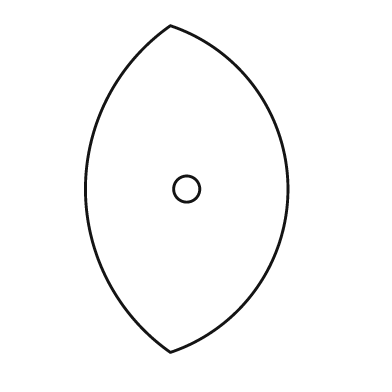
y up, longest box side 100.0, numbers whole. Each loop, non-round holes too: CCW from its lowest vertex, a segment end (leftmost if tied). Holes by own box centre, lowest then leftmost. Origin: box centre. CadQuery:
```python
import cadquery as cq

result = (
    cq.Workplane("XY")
    .moveTo(-5.0, -50.0)
    .threePointArc((31.0, 0.0), (-5.0, 50.0))
    .threePointArc((-31.0, 0.0), (-5.0, -50.0))
    .close()
    .moveTo(0.0, 0.0)
    .circle(4.0)
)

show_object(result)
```